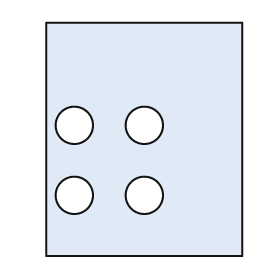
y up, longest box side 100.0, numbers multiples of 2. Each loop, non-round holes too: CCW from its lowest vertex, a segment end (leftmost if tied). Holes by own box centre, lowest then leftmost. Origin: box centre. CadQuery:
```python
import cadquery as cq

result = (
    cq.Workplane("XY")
    .moveTo(-42.0, -50.0)
    .lineTo(42.0, -50.0)
    .lineTo(42.0, 50.0)
    .lineTo(-42.0, 50.0)
    .close()
    .moveTo(-30.0, -24.0)
    .circle(8.0)
    .moveTo(0.0, -24.0)
    .circle(8.0)
    .moveTo(-30.0, 6.0)
    .circle(8.0)
    .moveTo(0.0, 6.0)
    .circle(8.0)
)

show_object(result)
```